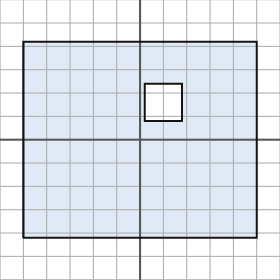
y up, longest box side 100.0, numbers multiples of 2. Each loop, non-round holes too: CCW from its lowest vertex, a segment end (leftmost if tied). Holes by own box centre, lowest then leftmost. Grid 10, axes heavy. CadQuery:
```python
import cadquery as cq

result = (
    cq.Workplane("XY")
    .moveTo(-50.0, -42.0)
    .lineTo(50.0, -42.0)
    .lineTo(50.0, 42.0)
    .lineTo(-50.0, 42.0)
    .close()
    .moveTo(2.0, 8.0)
    .lineTo(18.0, 8.0)
    .lineTo(18.0, 24.0)
    .lineTo(2.0, 24.0)
    .close()
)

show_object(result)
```